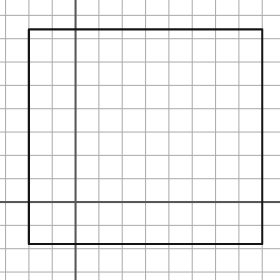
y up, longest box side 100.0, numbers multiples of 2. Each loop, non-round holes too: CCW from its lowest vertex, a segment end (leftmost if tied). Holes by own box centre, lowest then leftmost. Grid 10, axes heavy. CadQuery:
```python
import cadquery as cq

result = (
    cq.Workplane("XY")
    .moveTo(-20.0, -18.0)
    .lineTo(80.0, -18.0)
    .lineTo(80.0, 74.0)
    .lineTo(-20.0, 74.0)
    .close()
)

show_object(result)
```